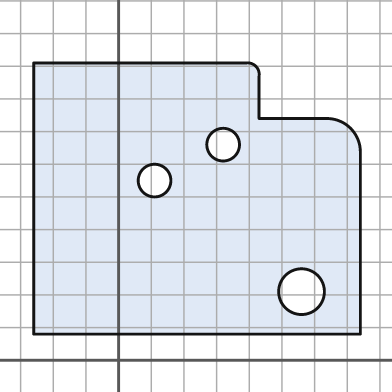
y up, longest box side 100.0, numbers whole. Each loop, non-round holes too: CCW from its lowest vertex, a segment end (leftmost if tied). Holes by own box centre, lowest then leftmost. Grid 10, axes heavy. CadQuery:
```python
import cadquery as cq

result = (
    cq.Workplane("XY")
    .moveTo(-26.0, 8.0)
    .lineTo(74.0, 8.0)
    .lineTo(74.0, 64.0)
    .threePointArc((71.0, 71.0), (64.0, 74.0))
    .lineTo(43.0, 74.0)
    .lineTo(43.0, 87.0)
    .threePointArc((42.0, 90.0), (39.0, 91.0))
    .lineTo(-26.0, 91.0)
    .close()
    .moveTo(56.0, 21.0)
    .circle(7.0)
    .moveTo(11.0, 55.0)
    .circle(5.0)
    .moveTo(32.0, 66.0)
    .circle(5.0)
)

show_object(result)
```